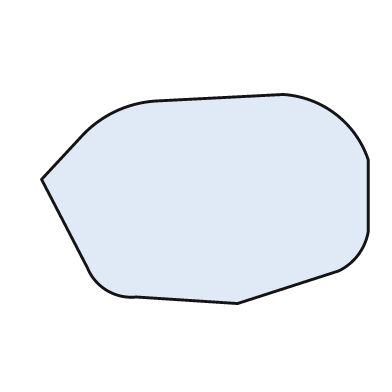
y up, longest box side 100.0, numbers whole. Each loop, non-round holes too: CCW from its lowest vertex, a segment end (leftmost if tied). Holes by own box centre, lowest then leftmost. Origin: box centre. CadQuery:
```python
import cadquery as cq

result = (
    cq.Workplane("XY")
    .moveTo(10.0, -32.0)
    .lineTo(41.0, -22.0)
    .threePointArc((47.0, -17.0), (50.0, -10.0))
    .lineTo(50.0, 12.0)
    .threePointArc((40.0, 26.0), (24.0, 32.0))
    .lineTo(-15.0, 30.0)
    .threePointArc((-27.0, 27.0), (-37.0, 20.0))
    .lineTo(-50.0, 6.0)
    .lineTo(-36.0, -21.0)
    .threePointArc((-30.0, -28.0), (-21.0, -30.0))
    .close()
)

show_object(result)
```